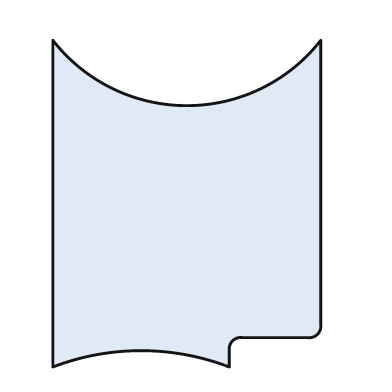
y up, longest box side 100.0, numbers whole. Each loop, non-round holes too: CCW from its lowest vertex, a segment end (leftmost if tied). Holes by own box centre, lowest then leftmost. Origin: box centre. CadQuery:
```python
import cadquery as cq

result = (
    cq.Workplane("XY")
    .moveTo(-41.0, -50.0)
    .threePointArc((-14.0, -45.0), (13.0, -50.0))
    .lineTo(13.0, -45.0)
    .threePointArc((14.0, -42.0), (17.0, -41.0))
    .lineTo(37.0, -41.0)
    .threePointArc((40.0, -40.0), (41.0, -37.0))
    .lineTo(41.0, 50.0)
    .threePointArc((0.0, 30.0), (-41.0, 50.0))
    .close()
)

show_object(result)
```